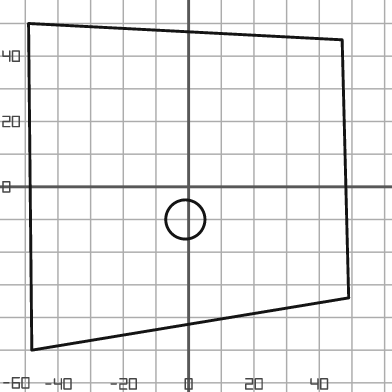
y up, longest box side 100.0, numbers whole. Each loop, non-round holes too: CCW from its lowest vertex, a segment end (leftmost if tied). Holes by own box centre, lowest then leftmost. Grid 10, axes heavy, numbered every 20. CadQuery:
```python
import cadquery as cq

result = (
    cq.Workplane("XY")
    .moveTo(-48.0, -50.0)
    .lineTo(49.0, -34.0)
    .lineTo(47.0, 45.0)
    .lineTo(-49.0, 50.0)
    .close()
    .moveTo(-1.0, -10.0)
    .circle(6.0)
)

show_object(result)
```